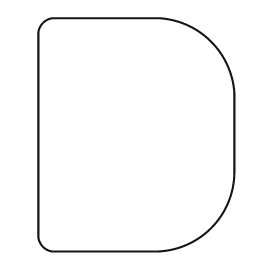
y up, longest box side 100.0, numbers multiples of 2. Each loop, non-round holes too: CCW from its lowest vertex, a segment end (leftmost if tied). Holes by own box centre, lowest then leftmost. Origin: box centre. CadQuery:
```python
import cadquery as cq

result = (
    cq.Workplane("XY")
    .moveTo(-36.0, -50.0)
    .lineTo(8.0, -50.0)
    .threePointArc((32.0, -40.0), (42.0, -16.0))
    .lineTo(42.0, 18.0)
    .threePointArc((32.0, 40.0), (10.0, 50.0))
    .lineTo(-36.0, 50.0)
    .threePointArc((-40.0, 48.0), (-42.0, 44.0))
    .lineTo(-42.0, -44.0)
    .threePointArc((-40.0, -48.0), (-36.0, -50.0))
    .close()
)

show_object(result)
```